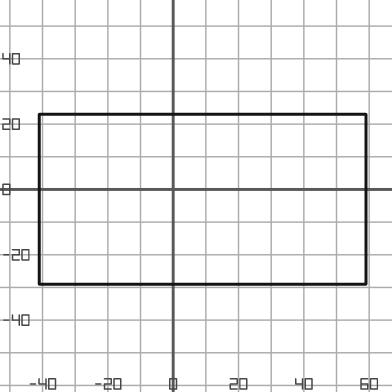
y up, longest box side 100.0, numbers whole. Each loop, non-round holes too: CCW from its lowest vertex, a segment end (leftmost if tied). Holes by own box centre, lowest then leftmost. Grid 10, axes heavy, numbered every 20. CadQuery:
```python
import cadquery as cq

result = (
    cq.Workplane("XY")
    .moveTo(-41.0, -29.0)
    .lineTo(59.0, -29.0)
    .lineTo(59.0, 23.0)
    .lineTo(-41.0, 23.0)
    .close()
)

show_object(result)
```